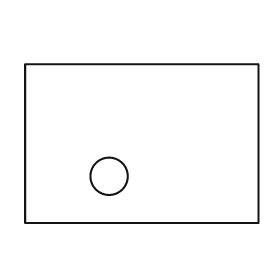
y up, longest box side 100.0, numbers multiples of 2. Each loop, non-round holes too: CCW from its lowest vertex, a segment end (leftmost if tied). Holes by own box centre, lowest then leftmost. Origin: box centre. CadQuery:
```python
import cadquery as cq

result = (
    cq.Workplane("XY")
    .moveTo(-50.0, -34.0)
    .lineTo(50.0, -34.0)
    .lineTo(50.0, 34.0)
    .lineTo(-50.0, 34.0)
    .close()
    .moveTo(-14.0, -14.0)
    .circle(8.0)
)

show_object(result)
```